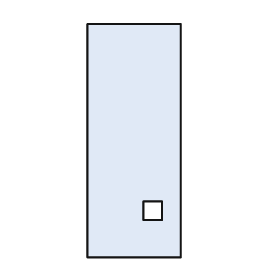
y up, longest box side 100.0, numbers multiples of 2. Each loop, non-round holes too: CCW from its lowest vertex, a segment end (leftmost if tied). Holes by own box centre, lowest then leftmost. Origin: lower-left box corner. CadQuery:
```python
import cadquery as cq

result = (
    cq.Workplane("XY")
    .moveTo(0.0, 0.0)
    .lineTo(40.0, 0.0)
    .lineTo(40.0, 100.0)
    .lineTo(0.0, 100.0)
    .close()
    .moveTo(24.0, 16.0)
    .lineTo(32.0, 16.0)
    .lineTo(32.0, 24.0)
    .lineTo(24.0, 24.0)
    .close()
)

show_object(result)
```